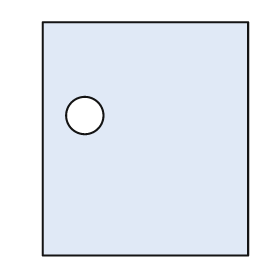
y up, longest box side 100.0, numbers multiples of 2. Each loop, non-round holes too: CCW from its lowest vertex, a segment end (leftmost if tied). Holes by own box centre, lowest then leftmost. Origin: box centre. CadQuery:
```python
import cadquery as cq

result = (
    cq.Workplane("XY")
    .moveTo(-44.0, -50.0)
    .lineTo(44.0, -50.0)
    .lineTo(44.0, 50.0)
    .lineTo(-44.0, 50.0)
    .close()
    .moveTo(-26.0, 10.0)
    .circle(8.0)
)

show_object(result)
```